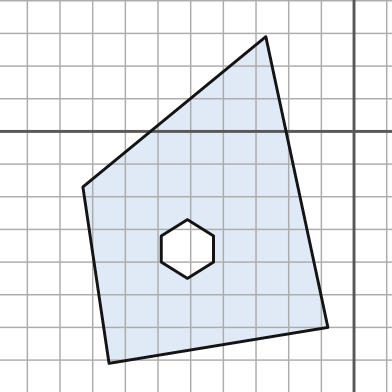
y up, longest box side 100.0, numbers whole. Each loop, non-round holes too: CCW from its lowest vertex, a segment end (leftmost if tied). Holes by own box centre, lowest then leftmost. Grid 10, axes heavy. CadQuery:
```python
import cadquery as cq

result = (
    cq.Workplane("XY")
    .moveTo(-75.0, -71.0)
    .lineTo(-8.0, -60.0)
    .lineTo(-27.0, 29.0)
    .lineTo(-83.0, -17.0)
    .close()
    .moveTo(-51.0, -45.0)
    .lineTo(-43.0, -40.0)
    .lineTo(-43.0, -32.0)
    .lineTo(-51.0, -27.0)
    .lineTo(-59.0, -32.0)
    .lineTo(-59.0, -40.0)
    .close()
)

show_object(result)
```